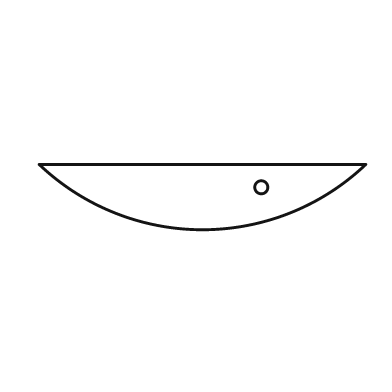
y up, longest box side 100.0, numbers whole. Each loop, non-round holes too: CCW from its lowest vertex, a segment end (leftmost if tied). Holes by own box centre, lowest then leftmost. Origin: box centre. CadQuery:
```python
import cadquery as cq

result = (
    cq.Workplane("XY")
    .moveTo(-50.0, 10.0)
    .threePointArc((0.0, -10.0), (50.0, 10.0))
    .close()
    .moveTo(18.0, 3.0)
    .circle(2.0)
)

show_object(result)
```